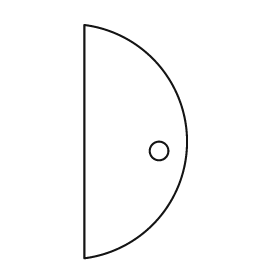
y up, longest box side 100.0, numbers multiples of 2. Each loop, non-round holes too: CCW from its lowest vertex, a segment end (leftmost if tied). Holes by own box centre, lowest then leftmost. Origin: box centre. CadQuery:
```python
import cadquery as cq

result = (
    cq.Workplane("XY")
    .moveTo(-22.0, -50.0)
    .threePointArc((22.0, 0.0), (-22.0, 50.0))
    .close()
    .moveTo(10.0, -4.0)
    .circle(4.0)
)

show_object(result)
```